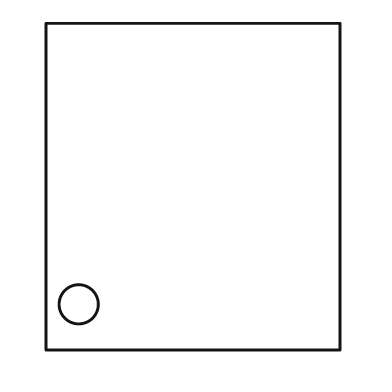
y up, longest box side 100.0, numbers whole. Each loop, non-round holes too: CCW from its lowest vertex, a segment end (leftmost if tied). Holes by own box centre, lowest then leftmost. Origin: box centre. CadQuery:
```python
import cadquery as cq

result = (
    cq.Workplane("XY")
    .moveTo(-45.0, -50.0)
    .lineTo(45.0, -50.0)
    .lineTo(45.0, 50.0)
    .lineTo(-45.0, 50.0)
    .close()
    .moveTo(-35.0, -36.0)
    .circle(6.0)
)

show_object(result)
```